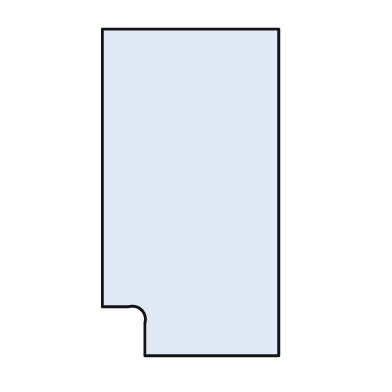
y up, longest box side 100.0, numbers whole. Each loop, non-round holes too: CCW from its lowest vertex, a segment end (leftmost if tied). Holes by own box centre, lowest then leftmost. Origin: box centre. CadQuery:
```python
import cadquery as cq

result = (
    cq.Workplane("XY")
    .moveTo(-14.0, -50.0)
    .lineTo(27.0, -50.0)
    .lineTo(27.0, 50.0)
    .lineTo(-27.0, 50.0)
    .lineTo(-27.0, -35.0)
    .lineTo(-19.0, -35.0)
    .threePointArc((-15.0, -36.0), (-14.0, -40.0))
    .close()
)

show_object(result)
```